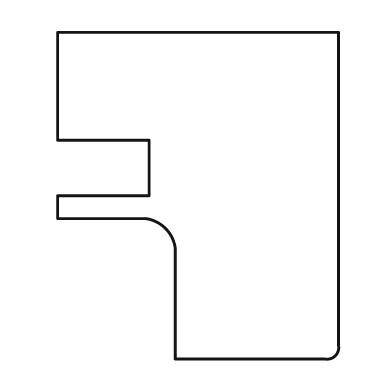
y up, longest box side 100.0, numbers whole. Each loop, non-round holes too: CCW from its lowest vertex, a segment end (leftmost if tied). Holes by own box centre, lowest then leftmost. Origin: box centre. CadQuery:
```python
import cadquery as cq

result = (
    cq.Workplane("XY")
    .moveTo(-7.0, -50.0)
    .lineTo(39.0, -50.0)
    .threePointArc((42.0, -49.0), (43.0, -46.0))
    .lineTo(43.0, 50.0)
    .lineTo(-43.0, 50.0)
    .lineTo(-43.0, 17.0)
    .lineTo(-15.0, 17.0)
    .lineTo(-15.0, 0.0)
    .lineTo(-43.0, 0.0)
    .lineTo(-43.0, -7.0)
    .lineTo(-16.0, -7.0)
    .threePointArc((-10.0, -10.0), (-7.0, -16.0))
    .close()
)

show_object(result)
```